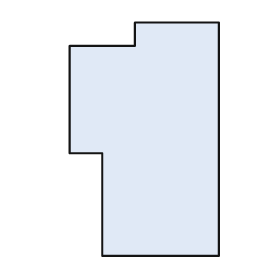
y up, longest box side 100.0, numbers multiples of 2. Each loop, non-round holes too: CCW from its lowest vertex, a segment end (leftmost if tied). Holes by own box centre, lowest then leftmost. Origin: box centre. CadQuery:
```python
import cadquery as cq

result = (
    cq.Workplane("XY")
    .moveTo(-18.0, -50.0)
    .lineTo(32.0, -50.0)
    .lineTo(32.0, 50.0)
    .lineTo(-4.0, 50.0)
    .lineTo(-4.0, 40.0)
    .lineTo(-32.0, 40.0)
    .lineTo(-32.0, -6.0)
    .lineTo(-18.0, -6.0)
    .close()
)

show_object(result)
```